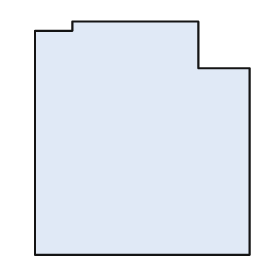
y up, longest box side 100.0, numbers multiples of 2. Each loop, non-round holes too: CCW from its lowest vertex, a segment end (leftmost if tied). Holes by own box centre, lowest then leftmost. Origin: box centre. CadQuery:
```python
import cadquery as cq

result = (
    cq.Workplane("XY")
    .moveTo(-46.0, -50.0)
    .lineTo(46.0, -50.0)
    .lineTo(46.0, 30.0)
    .lineTo(24.0, 30.0)
    .lineTo(24.0, 50.0)
    .lineTo(-30.0, 50.0)
    .lineTo(-30.0, 46.0)
    .lineTo(-46.0, 46.0)
    .close()
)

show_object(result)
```